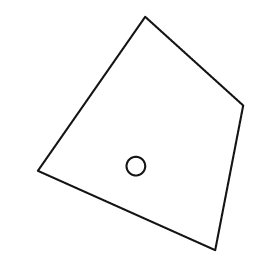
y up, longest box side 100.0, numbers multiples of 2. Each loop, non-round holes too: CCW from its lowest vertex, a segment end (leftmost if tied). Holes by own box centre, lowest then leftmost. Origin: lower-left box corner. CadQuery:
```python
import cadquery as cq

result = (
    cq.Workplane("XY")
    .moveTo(76.0, 0.0)
    .lineTo(88.0, 62.0)
    .lineTo(46.0, 100.0)
    .lineTo(0.0, 34.0)
    .close()
    .moveTo(42.0, 36.0)
    .circle(4.0)
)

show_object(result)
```